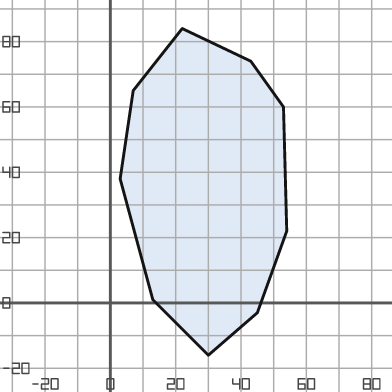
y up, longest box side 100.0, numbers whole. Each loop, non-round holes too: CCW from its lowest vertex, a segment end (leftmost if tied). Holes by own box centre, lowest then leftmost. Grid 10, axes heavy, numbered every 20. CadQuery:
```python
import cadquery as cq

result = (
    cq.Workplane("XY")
    .moveTo(30.0, -16.0)
    .lineTo(45.0, -3.0)
    .lineTo(54.0, 22.0)
    .lineTo(53.0, 60.0)
    .lineTo(43.0, 74.0)
    .lineTo(22.0, 84.0)
    .lineTo(7.0, 65.0)
    .lineTo(3.0, 38.0)
    .lineTo(13.0, 1.0)
    .close()
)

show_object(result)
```